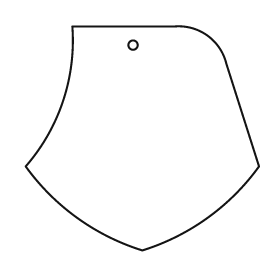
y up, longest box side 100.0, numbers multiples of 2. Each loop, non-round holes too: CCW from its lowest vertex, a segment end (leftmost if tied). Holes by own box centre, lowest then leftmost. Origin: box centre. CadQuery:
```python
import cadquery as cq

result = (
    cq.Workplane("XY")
    .moveTo(0.0, -48.0)
    .threePointArc((28.0, -34.0), (50.0, -12.0))
    .lineTo(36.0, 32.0)
    .threePointArc((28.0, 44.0), (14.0, 48.0))
    .lineTo(-30.0, 48.0)
    .threePointArc((-34.0, 16.0), (-50.0, -12.0))
    .threePointArc((-28.0, -34.0), (0.0, -48.0))
    .close()
    .moveTo(-4.0, 40.0)
    .circle(2.0)
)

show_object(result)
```